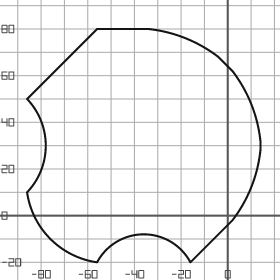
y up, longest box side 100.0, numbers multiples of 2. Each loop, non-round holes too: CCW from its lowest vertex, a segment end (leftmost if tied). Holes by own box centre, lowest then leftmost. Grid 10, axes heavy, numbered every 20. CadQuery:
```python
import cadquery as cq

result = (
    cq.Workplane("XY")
    .moveTo(-56.0, -20.0)
    .threePointArc((-36.0, -8.0), (-16.0, -20.0))
    .lineTo(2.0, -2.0)
    .threePointArc((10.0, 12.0), (14.0, 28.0))
    .lineTo(14.0, 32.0)
    .threePointArc((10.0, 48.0), (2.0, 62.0))
    .lineTo(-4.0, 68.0)
    .threePointArc((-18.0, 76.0), (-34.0, 80.0))
    .lineTo(-56.0, 80.0)
    .lineTo(-86.0, 50.0)
    .threePointArc((-78.0, 30.0), (-86.0, 10.0))
    .threePointArc((-76.0, -10.0), (-56.0, -20.0))
    .close()
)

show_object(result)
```